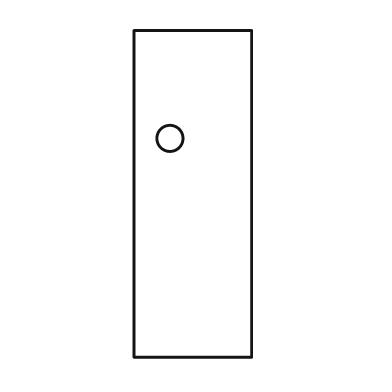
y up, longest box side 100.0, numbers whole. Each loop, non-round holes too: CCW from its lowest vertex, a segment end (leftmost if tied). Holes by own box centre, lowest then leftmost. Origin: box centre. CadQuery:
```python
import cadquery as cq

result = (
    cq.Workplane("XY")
    .moveTo(-18.0, -50.0)
    .lineTo(18.0, -50.0)
    .lineTo(18.0, 50.0)
    .lineTo(-18.0, 50.0)
    .close()
    .moveTo(-7.0, 17.0)
    .circle(4.0)
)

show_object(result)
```